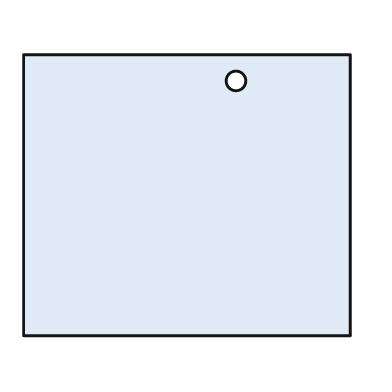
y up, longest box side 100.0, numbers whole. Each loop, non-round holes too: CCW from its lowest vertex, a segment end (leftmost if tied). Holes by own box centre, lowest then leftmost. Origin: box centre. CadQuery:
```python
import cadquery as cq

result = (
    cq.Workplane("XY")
    .moveTo(-50.0, -43.0)
    .lineTo(50.0, -43.0)
    .lineTo(50.0, 43.0)
    .lineTo(-50.0, 43.0)
    .close()
    .moveTo(15.0, 35.0)
    .circle(3.0)
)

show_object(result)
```